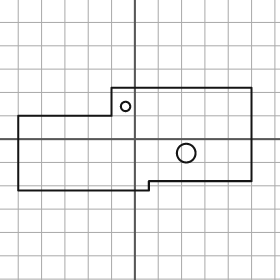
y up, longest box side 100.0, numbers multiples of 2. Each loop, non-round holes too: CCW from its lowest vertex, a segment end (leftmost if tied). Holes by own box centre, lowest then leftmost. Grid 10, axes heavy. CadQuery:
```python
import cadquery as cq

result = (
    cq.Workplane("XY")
    .moveTo(-50.0, -22.0)
    .lineTo(6.0, -22.0)
    .lineTo(6.0, -18.0)
    .lineTo(50.0, -18.0)
    .lineTo(50.0, 22.0)
    .lineTo(-10.0, 22.0)
    .lineTo(-10.0, 10.0)
    .lineTo(-50.0, 10.0)
    .close()
    .moveTo(22.0, -6.0)
    .circle(4.0)
    .moveTo(-4.0, 14.0)
    .circle(2.0)
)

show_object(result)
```